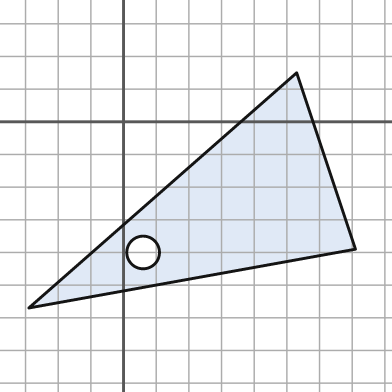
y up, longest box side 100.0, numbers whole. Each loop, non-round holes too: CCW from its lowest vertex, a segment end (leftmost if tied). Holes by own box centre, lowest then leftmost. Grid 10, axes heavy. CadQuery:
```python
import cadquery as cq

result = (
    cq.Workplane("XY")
    .moveTo(-29.0, -57.0)
    .lineTo(71.0, -39.0)
    .lineTo(53.0, 15.0)
    .close()
    .moveTo(6.0, -40.0)
    .circle(5.0)
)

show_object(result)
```